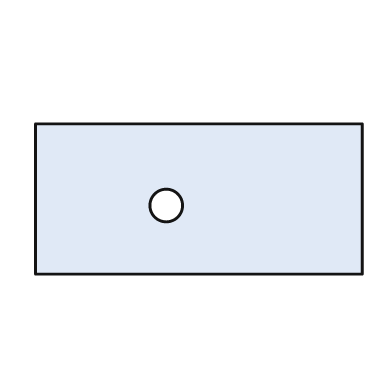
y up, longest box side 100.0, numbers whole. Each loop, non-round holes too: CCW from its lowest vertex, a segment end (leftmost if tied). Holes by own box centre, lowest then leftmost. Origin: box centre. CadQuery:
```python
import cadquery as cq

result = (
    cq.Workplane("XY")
    .moveTo(-50.0, -23.0)
    .lineTo(50.0, -23.0)
    .lineTo(50.0, 23.0)
    .lineTo(-50.0, 23.0)
    .close()
    .moveTo(-10.0, -2.0)
    .circle(5.0)
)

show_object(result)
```